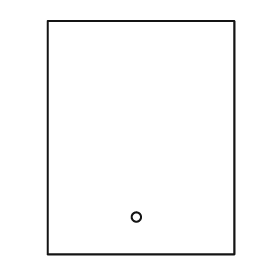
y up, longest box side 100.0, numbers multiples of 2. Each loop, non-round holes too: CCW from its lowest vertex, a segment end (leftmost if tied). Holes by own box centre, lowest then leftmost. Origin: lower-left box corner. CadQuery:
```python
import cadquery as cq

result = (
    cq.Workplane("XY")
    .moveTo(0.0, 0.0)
    .lineTo(80.0, 0.0)
    .lineTo(80.0, 100.0)
    .lineTo(0.0, 100.0)
    .close()
    .moveTo(38.0, 16.0)
    .circle(2.0)
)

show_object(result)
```